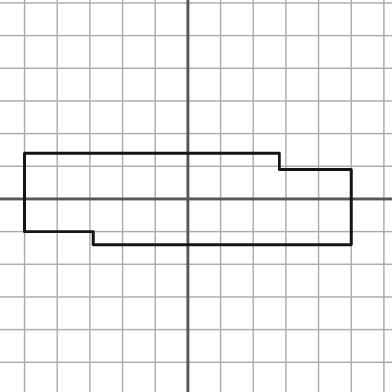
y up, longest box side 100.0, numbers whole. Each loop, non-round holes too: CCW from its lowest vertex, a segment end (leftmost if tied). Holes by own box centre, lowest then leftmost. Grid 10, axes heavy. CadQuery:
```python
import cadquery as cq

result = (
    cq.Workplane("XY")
    .moveTo(-29.0, -14.0)
    .lineTo(50.0, -14.0)
    .lineTo(50.0, 9.0)
    .lineTo(28.0, 9.0)
    .lineTo(28.0, 14.0)
    .lineTo(-50.0, 14.0)
    .lineTo(-50.0, -10.0)
    .lineTo(-29.0, -10.0)
    .close()
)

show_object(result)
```